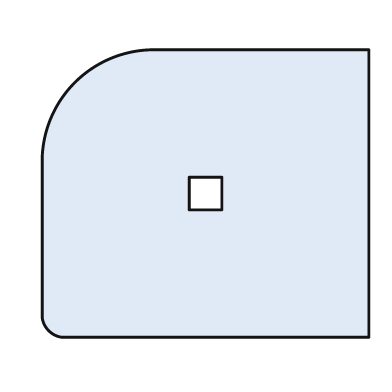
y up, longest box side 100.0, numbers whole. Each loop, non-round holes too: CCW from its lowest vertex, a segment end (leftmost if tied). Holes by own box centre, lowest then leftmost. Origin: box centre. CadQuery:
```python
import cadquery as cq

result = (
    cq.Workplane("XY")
    .moveTo(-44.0, -44.0)
    .lineTo(50.0, -44.0)
    .lineTo(50.0, 44.0)
    .lineTo(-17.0, 44.0)
    .threePointArc((-40.0, 34.0), (-50.0, 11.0))
    .lineTo(-50.0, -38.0)
    .threePointArc((-48.0, -42.0), (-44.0, -44.0))
    .close()
    .moveTo(-5.0, -5.0)
    .lineTo(5.0, -5.0)
    .lineTo(5.0, 5.0)
    .lineTo(-5.0, 5.0)
    .close()
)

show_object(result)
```